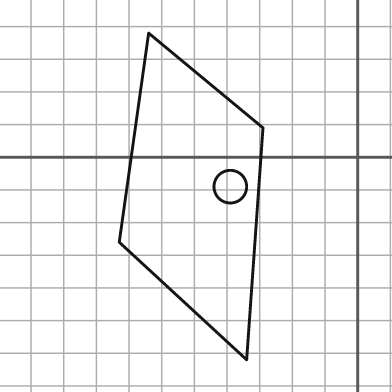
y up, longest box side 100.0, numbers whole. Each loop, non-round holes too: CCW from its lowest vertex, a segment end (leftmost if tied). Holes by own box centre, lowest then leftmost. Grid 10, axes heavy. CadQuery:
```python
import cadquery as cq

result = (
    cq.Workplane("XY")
    .moveTo(-34.0, -62.0)
    .lineTo(-29.0, 9.0)
    .lineTo(-64.0, 38.0)
    .lineTo(-73.0, -26.0)
    .close()
    .moveTo(-39.0, -9.0)
    .circle(5.0)
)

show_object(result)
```